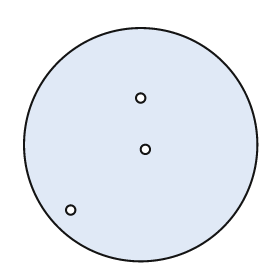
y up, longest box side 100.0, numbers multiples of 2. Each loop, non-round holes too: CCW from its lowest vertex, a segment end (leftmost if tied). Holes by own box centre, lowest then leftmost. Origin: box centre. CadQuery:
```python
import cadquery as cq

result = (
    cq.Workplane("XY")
    .moveTo(0.0, 0.0)
    .circle(50.0)
    .moveTo(-30.0, -28.0)
    .circle(2.0)
    .moveTo(2.0, -2.0)
    .circle(2.0)
    .moveTo(0.0, 20.0)
    .circle(2.0)
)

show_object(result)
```